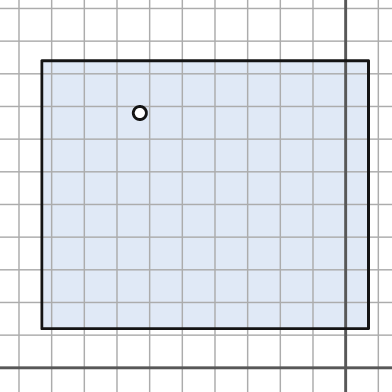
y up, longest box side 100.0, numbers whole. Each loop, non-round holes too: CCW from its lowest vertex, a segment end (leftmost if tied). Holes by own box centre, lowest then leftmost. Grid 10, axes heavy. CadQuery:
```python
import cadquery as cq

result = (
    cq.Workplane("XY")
    .moveTo(-93.0, 12.0)
    .lineTo(7.0, 12.0)
    .lineTo(7.0, 94.0)
    .lineTo(-93.0, 94.0)
    .close()
    .moveTo(-63.0, 78.0)
    .circle(2.0)
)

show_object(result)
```